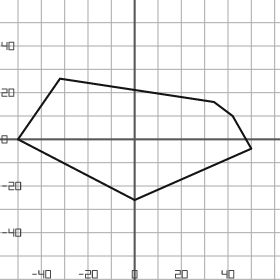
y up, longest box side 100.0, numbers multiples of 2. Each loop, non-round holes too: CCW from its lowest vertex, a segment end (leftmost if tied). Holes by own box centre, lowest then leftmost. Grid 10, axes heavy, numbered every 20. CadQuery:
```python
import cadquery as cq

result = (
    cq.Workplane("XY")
    .moveTo(0.0, -26.0)
    .lineTo(50.0, -4.0)
    .lineTo(42.0, 10.0)
    .lineTo(34.0, 16.0)
    .lineTo(-32.0, 26.0)
    .lineTo(-50.0, 0.0)
    .close()
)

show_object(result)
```